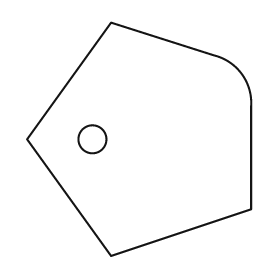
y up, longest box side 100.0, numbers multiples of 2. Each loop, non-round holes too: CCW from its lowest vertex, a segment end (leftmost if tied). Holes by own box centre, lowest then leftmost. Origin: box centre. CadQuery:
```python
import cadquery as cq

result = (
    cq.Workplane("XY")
    .moveTo(-12.0, -50.0)
    .lineTo(48.0, -30.0)
    .lineTo(48.0, 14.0)
    .threePointArc((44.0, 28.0), (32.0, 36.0))
    .lineTo(-12.0, 50.0)
    .lineTo(-48.0, 0.0)
    .close()
    .moveTo(-20.0, 0.0)
    .circle(6.0)
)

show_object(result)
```